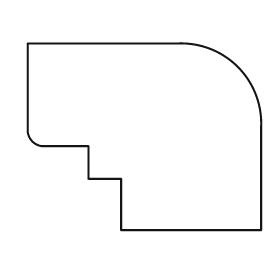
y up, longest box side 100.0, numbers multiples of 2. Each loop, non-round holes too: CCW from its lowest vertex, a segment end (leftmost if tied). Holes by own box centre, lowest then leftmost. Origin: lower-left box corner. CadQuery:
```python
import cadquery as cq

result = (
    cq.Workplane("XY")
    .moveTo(40.0, 0.0)
    .lineTo(100.0, 0.0)
    .lineTo(100.0, 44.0)
    .threePointArc((90.0, 70.0), (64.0, 80.0))
    .lineTo(0.0, 80.0)
    .lineTo(0.0, 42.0)
    .threePointArc((2.0, 38.0), (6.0, 36.0))
    .lineTo(26.0, 36.0)
    .lineTo(26.0, 22.0)
    .lineTo(40.0, 22.0)
    .close()
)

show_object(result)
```